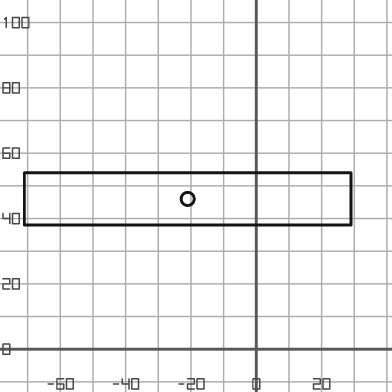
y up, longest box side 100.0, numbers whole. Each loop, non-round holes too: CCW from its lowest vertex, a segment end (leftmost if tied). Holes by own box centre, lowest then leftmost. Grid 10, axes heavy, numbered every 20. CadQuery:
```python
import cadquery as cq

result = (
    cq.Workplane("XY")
    .moveTo(-71.0, 38.0)
    .lineTo(29.0, 38.0)
    .lineTo(29.0, 54.0)
    .lineTo(-71.0, 54.0)
    .close()
    .moveTo(-21.0, 46.0)
    .circle(2.0)
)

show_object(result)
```